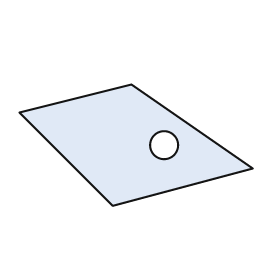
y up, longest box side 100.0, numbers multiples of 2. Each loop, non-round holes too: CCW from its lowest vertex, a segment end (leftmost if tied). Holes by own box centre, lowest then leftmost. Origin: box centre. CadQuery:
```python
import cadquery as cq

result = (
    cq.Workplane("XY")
    .moveTo(-10.0, -26.0)
    .lineTo(50.0, -10.0)
    .lineTo(-2.0, 26.0)
    .lineTo(-50.0, 14.0)
    .close()
    .moveTo(12.0, 0.0)
    .circle(6.0)
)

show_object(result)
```